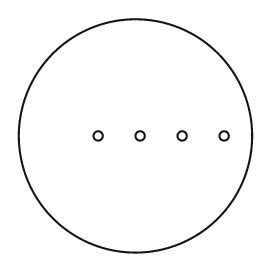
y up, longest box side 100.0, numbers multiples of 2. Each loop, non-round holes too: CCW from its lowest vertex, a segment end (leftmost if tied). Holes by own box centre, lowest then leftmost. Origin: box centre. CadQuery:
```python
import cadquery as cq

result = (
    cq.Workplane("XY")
    .moveTo(0.0, 0.0)
    .circle(50.0)
    .moveTo(-16.0, 0.0)
    .circle(2.0)
    .moveTo(2.0, 0.0)
    .circle(2.0)
    .moveTo(20.0, 0.0)
    .circle(2.0)
    .moveTo(38.0, 0.0)
    .circle(2.0)
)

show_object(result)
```